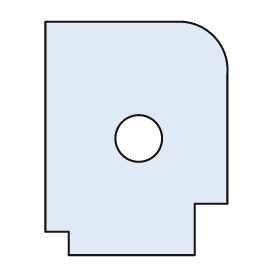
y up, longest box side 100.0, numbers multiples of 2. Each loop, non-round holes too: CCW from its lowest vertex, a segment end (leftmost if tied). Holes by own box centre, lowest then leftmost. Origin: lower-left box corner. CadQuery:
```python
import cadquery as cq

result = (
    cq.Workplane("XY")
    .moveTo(10.0, 0.0)
    .lineTo(64.0, 0.0)
    .lineTo(64.0, 22.0)
    .lineTo(78.0, 22.0)
    .lineTo(78.0, 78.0)
    .threePointArc((72.0, 94.0), (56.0, 100.0))
    .lineTo(0.0, 100.0)
    .lineTo(0.0, 10.0)
    .lineTo(10.0, 10.0)
    .close()
    .moveTo(40.0, 50.0)
    .circle(10.0)
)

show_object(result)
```